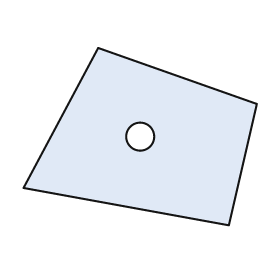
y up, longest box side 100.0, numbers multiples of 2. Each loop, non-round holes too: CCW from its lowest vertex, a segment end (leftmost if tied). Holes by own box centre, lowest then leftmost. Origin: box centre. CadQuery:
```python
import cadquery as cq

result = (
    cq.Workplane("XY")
    .moveTo(38.0, -38.0)
    .lineTo(50.0, 14.0)
    .lineTo(-18.0, 38.0)
    .lineTo(-50.0, -22.0)
    .close()
    .moveTo(0.0, 0.0)
    .circle(6.0)
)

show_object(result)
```